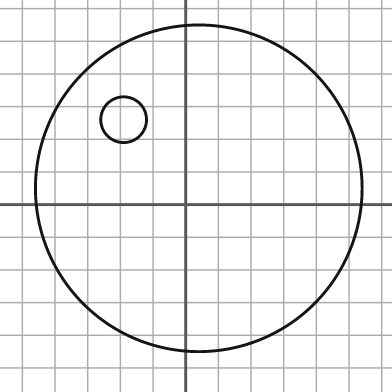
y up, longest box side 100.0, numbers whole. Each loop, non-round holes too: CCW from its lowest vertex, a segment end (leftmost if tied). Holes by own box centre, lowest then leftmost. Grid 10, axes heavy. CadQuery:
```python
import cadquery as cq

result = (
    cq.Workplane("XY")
    .moveTo(4.0, 5.0)
    .circle(50.0)
    .moveTo(-19.0, 26.0)
    .circle(7.0)
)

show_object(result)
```